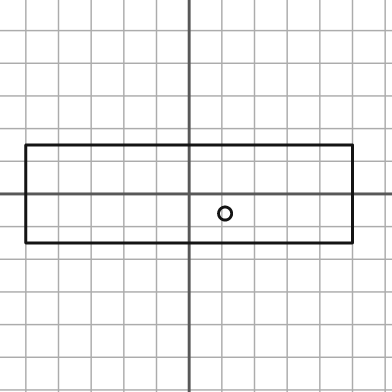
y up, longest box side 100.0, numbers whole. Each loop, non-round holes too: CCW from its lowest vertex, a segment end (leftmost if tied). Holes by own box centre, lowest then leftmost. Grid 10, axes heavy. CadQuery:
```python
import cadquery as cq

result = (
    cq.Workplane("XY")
    .moveTo(-50.0, -15.0)
    .lineTo(50.0, -15.0)
    .lineTo(50.0, 15.0)
    .lineTo(-50.0, 15.0)
    .close()
    .moveTo(11.0, -6.0)
    .circle(2.0)
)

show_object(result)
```